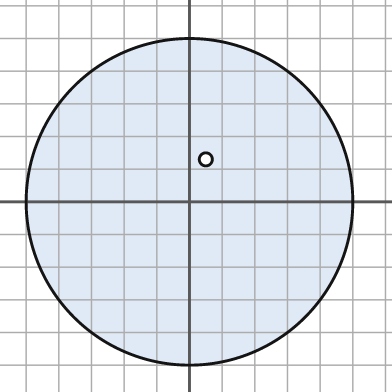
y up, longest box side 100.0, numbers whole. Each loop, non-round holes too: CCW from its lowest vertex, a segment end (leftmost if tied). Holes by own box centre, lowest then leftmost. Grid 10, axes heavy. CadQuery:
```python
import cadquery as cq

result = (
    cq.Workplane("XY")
    .moveTo(0.0, 0.0)
    .circle(50.0)
    .moveTo(5.0, 13.0)
    .circle(2.0)
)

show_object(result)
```